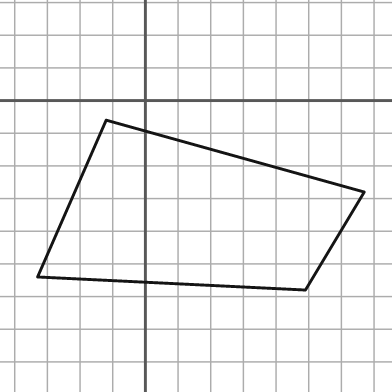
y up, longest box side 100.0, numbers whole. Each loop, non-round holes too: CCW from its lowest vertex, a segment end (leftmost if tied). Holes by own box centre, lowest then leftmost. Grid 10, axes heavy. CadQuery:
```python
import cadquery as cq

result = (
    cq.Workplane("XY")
    .moveTo(49.0, -58.0)
    .lineTo(67.0, -28.0)
    .lineTo(-12.0, -6.0)
    .lineTo(-33.0, -54.0)
    .close()
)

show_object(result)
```